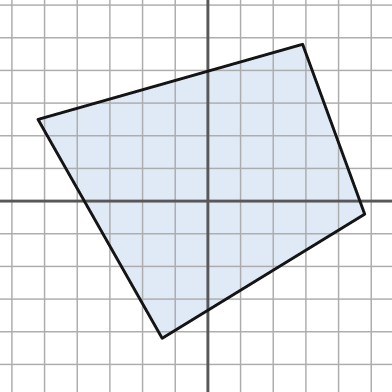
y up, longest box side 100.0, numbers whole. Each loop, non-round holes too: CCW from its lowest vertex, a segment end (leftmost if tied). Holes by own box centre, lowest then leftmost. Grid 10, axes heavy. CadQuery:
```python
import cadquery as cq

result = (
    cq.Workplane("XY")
    .moveTo(-14.0, -42.0)
    .lineTo(48.0, -4.0)
    .lineTo(29.0, 48.0)
    .lineTo(-52.0, 25.0)
    .close()
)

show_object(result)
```